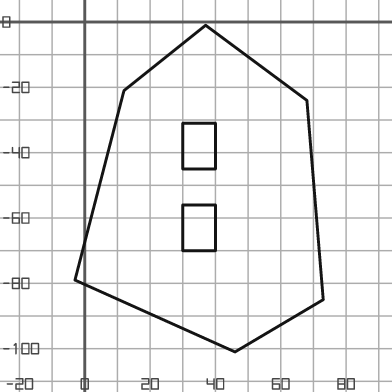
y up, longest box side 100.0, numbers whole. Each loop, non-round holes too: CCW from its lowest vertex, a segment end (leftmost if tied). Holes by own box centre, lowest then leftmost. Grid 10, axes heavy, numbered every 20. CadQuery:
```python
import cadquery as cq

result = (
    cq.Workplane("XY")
    .moveTo(46.0, -101.0)
    .lineTo(73.0, -85.0)
    .lineTo(68.0, -24.0)
    .lineTo(37.0, -1.0)
    .lineTo(12.0, -21.0)
    .lineTo(-3.0, -79.0)
    .close()
    .moveTo(30.0, -70.0)
    .lineTo(40.0, -70.0)
    .lineTo(40.0, -56.0)
    .lineTo(30.0, -56.0)
    .close()
    .moveTo(30.0, -45.0)
    .lineTo(40.0, -45.0)
    .lineTo(40.0, -31.0)
    .lineTo(30.0, -31.0)
    .close()
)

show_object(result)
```